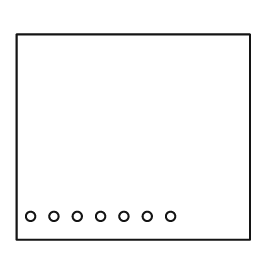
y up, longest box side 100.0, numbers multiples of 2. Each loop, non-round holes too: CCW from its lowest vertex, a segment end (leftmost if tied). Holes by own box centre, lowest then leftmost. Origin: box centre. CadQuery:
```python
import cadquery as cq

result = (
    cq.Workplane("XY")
    .moveTo(-50.0, -44.0)
    .lineTo(50.0, -44.0)
    .lineTo(50.0, 44.0)
    .lineTo(-50.0, 44.0)
    .close()
    .moveTo(-44.0, -34.0)
    .circle(2.0)
    .moveTo(-34.0, -34.0)
    .circle(2.0)
    .moveTo(-24.0, -34.0)
    .circle(2.0)
    .moveTo(-14.0, -34.0)
    .circle(2.0)
    .moveTo(-4.0, -34.0)
    .circle(2.0)
    .moveTo(6.0, -34.0)
    .circle(2.0)
    .moveTo(16.0, -34.0)
    .circle(2.0)
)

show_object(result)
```